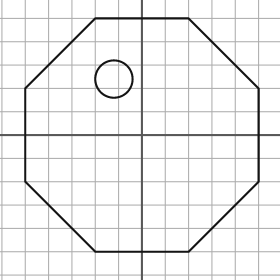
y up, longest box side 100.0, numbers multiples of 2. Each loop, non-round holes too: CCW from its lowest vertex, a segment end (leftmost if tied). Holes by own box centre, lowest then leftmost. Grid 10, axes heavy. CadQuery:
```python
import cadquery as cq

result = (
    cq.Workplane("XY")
    .moveTo(-20.0, -50.0)
    .lineTo(20.0, -50.0)
    .lineTo(50.0, -20.0)
    .lineTo(50.0, 20.0)
    .lineTo(20.0, 50.0)
    .lineTo(-20.0, 50.0)
    .lineTo(-50.0, 20.0)
    .lineTo(-50.0, -20.0)
    .close()
    .moveTo(-12.0, 24.0)
    .circle(8.0)
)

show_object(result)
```